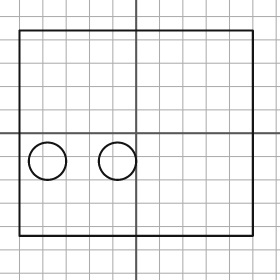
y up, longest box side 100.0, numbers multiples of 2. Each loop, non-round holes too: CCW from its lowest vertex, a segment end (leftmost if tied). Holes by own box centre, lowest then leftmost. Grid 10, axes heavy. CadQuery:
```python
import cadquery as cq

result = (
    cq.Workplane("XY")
    .moveTo(-50.0, -44.0)
    .lineTo(50.0, -44.0)
    .lineTo(50.0, 44.0)
    .lineTo(-50.0, 44.0)
    .close()
    .moveTo(-38.0, -12.0)
    .circle(8.0)
    .moveTo(-8.0, -12.0)
    .circle(8.0)
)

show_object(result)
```